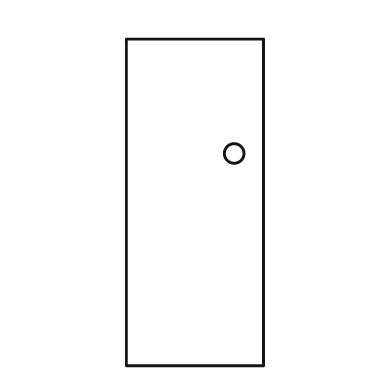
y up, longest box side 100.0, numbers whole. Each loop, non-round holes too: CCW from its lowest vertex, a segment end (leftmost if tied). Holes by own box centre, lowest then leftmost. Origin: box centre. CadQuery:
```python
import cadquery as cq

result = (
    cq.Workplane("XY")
    .moveTo(-21.0, -50.0)
    .lineTo(21.0, -50.0)
    .lineTo(21.0, 50.0)
    .lineTo(-21.0, 50.0)
    .close()
    .moveTo(12.0, 15.0)
    .circle(3.0)
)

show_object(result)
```